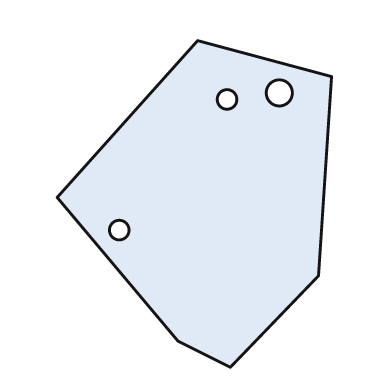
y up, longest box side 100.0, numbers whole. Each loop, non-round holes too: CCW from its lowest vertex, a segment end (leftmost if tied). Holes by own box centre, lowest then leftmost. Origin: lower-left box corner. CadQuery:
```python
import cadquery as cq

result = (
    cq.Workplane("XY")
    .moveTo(53.0, 0.0)
    .lineTo(80.0, 28.0)
    .lineTo(84.0, 89.0)
    .lineTo(43.0, 100.0)
    .lineTo(0.0, 52.0)
    .lineTo(37.0, 8.0)
    .close()
    .moveTo(19.0, 42.0)
    .circle(3.0)
    .moveTo(52.0, 82.0)
    .circle(3.0)
    .moveTo(68.0, 84.0)
    .circle(4.0)
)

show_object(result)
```